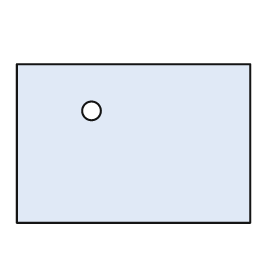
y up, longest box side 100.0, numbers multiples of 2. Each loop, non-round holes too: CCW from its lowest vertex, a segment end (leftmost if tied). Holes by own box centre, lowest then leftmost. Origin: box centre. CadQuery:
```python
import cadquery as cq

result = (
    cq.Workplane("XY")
    .moveTo(-50.0, -34.0)
    .lineTo(50.0, -34.0)
    .lineTo(50.0, 34.0)
    .lineTo(-50.0, 34.0)
    .close()
    .moveTo(-18.0, 14.0)
    .circle(4.0)
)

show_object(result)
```